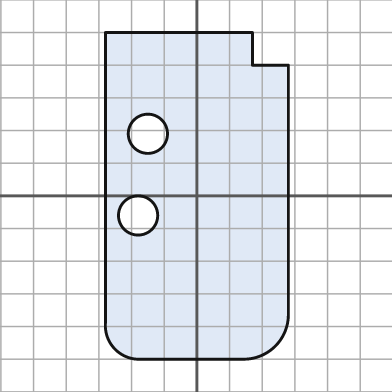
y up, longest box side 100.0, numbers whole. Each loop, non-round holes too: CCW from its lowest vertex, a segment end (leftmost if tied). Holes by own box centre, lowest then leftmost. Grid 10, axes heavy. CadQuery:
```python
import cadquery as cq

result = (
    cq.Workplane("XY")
    .moveTo(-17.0, -50.0)
    .lineTo(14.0, -50.0)
    .threePointArc((24.0, -46.0), (28.0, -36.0))
    .lineTo(28.0, 40.0)
    .lineTo(17.0, 40.0)
    .lineTo(17.0, 50.0)
    .lineTo(-28.0, 50.0)
    .lineTo(-28.0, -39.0)
    .threePointArc((-25.0, -47.0), (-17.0, -50.0))
    .close()
    .moveTo(-18.0, -6.0)
    .circle(6.0)
    .moveTo(-15.0, 19.0)
    .circle(6.0)
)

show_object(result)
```